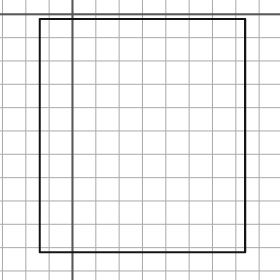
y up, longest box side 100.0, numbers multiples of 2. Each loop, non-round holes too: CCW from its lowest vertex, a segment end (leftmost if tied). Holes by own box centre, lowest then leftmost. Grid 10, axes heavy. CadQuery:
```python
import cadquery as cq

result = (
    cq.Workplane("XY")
    .moveTo(-14.0, -102.0)
    .lineTo(74.0, -102.0)
    .lineTo(74.0, -2.0)
    .lineTo(-14.0, -2.0)
    .close()
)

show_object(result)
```